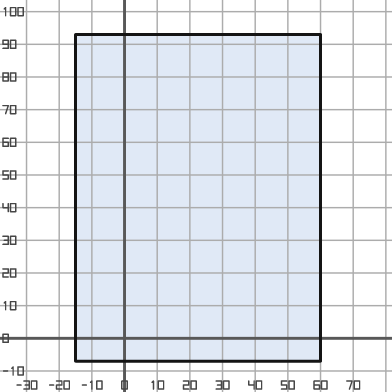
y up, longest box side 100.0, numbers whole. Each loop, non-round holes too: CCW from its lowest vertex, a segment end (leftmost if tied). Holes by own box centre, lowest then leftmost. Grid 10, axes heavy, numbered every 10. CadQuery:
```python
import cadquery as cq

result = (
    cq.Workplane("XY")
    .moveTo(-15.0, -7.0)
    .lineTo(60.0, -7.0)
    .lineTo(60.0, 93.0)
    .lineTo(-15.0, 93.0)
    .close()
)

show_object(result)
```